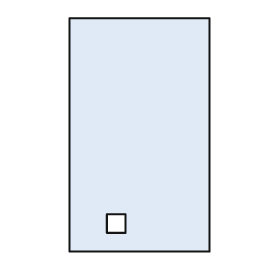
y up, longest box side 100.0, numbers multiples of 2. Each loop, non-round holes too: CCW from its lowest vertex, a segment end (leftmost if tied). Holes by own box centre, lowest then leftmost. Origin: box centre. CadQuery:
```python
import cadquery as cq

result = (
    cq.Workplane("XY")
    .moveTo(-30.0, -50.0)
    .lineTo(30.0, -50.0)
    .lineTo(30.0, 50.0)
    .lineTo(-30.0, 50.0)
    .close()
    .moveTo(-14.0, -42.0)
    .lineTo(-6.0, -42.0)
    .lineTo(-6.0, -34.0)
    .lineTo(-14.0, -34.0)
    .close()
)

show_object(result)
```